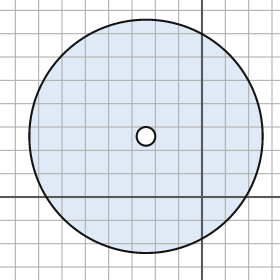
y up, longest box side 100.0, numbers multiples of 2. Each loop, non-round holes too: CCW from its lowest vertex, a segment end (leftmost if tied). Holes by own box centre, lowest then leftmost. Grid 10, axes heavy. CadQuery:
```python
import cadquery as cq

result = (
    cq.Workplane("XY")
    .moveTo(-24.0, 26.0)
    .circle(50.0)
    .moveTo(-24.0, 26.0)
    .circle(4.0)
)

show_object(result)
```